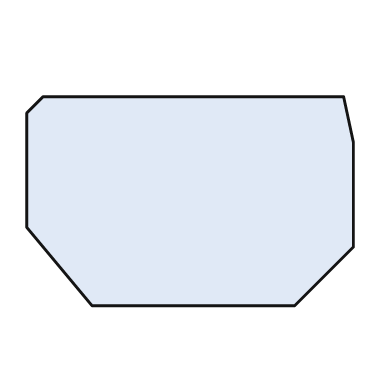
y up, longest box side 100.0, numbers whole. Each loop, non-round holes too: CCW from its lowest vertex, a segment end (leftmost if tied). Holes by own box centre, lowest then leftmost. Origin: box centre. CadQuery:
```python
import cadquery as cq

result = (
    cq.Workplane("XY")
    .moveTo(-30.0, -32.0)
    .lineTo(32.0, -32.0)
    .lineTo(50.0, -14.0)
    .lineTo(50.0, 18.0)
    .lineTo(47.0, 32.0)
    .lineTo(-45.0, 32.0)
    .lineTo(-50.0, 27.0)
    .lineTo(-50.0, -8.0)
    .close()
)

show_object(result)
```